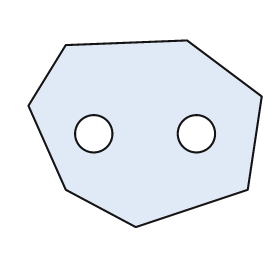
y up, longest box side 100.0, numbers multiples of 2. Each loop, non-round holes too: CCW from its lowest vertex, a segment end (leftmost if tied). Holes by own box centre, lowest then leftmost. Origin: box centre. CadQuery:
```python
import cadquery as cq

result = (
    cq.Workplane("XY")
    .moveTo(-4.0, -40.0)
    .lineTo(44.0, -24.0)
    .lineTo(50.0, 16.0)
    .lineTo(18.0, 40.0)
    .lineTo(-34.0, 38.0)
    .lineTo(-50.0, 12.0)
    .lineTo(-34.0, -24.0)
    .close()
    .moveTo(-22.0, 0.0)
    .circle(8.0)
    .moveTo(22.0, 0.0)
    .circle(8.0)
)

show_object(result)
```